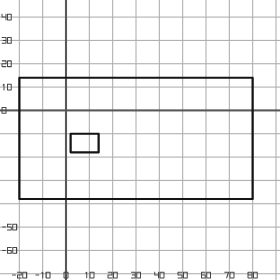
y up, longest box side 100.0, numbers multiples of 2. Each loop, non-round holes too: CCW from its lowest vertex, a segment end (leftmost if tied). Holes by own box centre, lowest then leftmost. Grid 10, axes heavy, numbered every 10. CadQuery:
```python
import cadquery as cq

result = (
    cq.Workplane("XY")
    .moveTo(-20.0, -38.0)
    .lineTo(80.0, -38.0)
    .lineTo(80.0, 14.0)
    .lineTo(-20.0, 14.0)
    .close()
    .moveTo(2.0, -18.0)
    .lineTo(14.0, -18.0)
    .lineTo(14.0, -10.0)
    .lineTo(2.0, -10.0)
    .close()
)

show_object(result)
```